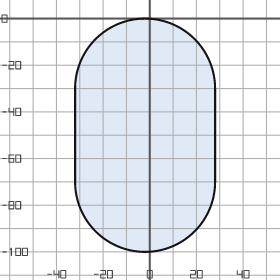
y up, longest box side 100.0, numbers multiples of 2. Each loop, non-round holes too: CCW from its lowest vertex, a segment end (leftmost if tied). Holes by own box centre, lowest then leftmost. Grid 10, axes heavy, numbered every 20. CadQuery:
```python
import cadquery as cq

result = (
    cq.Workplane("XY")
    .moveTo(-32.0, -70.0)
    .threePointArc((-2.0, -100.0), (28.0, -70.0))
    .lineTo(28.0, -30.0)
    .threePointArc((-2.0, 0.0), (-32.0, -30.0))
    .close()
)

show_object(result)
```